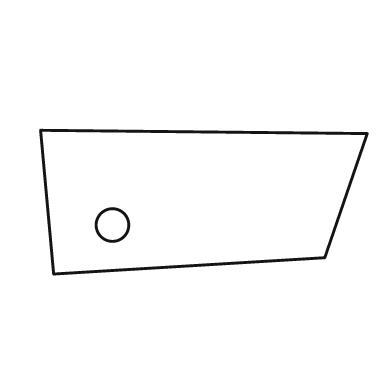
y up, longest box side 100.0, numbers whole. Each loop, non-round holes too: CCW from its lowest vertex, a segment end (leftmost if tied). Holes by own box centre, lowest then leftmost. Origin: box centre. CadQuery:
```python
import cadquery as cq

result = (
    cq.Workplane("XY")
    .moveTo(-46.0, -22.0)
    .lineTo(37.0, -17.0)
    .lineTo(50.0, 21.0)
    .lineTo(-50.0, 22.0)
    .close()
    .moveTo(-28.0, -7.0)
    .circle(5.0)
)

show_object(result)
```